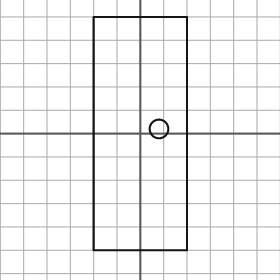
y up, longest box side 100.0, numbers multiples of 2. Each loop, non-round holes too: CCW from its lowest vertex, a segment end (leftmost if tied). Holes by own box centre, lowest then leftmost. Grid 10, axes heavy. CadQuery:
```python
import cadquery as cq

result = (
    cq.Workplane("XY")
    .moveTo(-20.0, -50.0)
    .lineTo(20.0, -50.0)
    .lineTo(20.0, 50.0)
    .lineTo(-20.0, 50.0)
    .close()
    .moveTo(8.0, 2.0)
    .circle(4.0)
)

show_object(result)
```